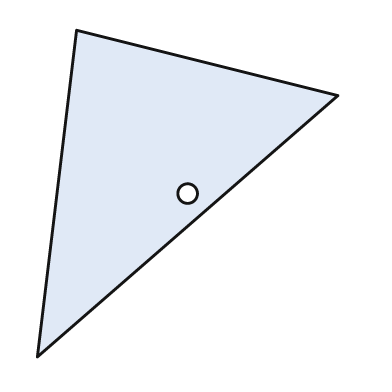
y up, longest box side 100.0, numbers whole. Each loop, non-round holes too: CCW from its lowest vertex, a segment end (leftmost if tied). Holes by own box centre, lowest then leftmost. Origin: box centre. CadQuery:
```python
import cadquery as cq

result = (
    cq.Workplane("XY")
    .moveTo(-46.0, -50.0)
    .lineTo(46.0, 30.0)
    .lineTo(-34.0, 50.0)
    .close()
    .moveTo(0.0, 0.0)
    .circle(3.0)
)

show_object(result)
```